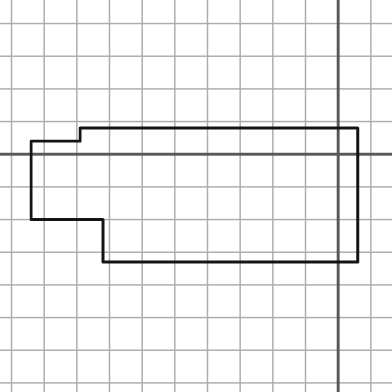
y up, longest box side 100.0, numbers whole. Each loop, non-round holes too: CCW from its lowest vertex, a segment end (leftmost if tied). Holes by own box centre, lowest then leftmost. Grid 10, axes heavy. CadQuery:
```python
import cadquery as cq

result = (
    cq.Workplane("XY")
    .moveTo(-72.0, -33.0)
    .lineTo(6.0, -33.0)
    .lineTo(6.0, 8.0)
    .lineTo(-79.0, 8.0)
    .lineTo(-79.0, 4.0)
    .lineTo(-94.0, 4.0)
    .lineTo(-94.0, -20.0)
    .lineTo(-72.0, -20.0)
    .close()
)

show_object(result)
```